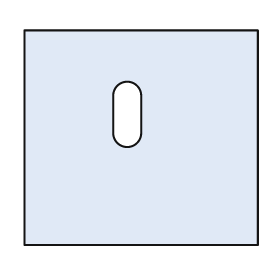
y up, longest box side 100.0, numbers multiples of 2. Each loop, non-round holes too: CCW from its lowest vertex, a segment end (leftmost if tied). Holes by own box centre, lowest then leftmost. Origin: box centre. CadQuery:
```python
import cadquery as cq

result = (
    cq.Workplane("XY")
    .moveTo(-50.0, -46.0)
    .lineTo(50.0, -46.0)
    .lineTo(50.0, 46.0)
    .lineTo(-50.0, 46.0)
    .close()
    .moveTo(-12.0, 2.0)
    .threePointArc((-6.0, -4.0), (0.0, 2.0))
    .lineTo(0.0, 18.0)
    .threePointArc((-6.0, 24.0), (-12.0, 18.0))
    .close()
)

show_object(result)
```